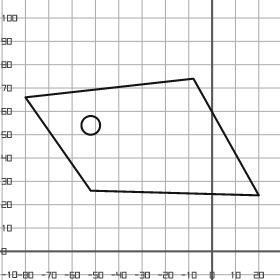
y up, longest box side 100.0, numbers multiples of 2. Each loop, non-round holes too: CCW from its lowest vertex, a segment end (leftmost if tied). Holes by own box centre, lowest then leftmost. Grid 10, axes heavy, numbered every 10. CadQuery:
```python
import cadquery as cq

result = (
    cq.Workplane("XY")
    .moveTo(20.0, 24.0)
    .lineTo(-8.0, 74.0)
    .lineTo(-80.0, 66.0)
    .lineTo(-52.0, 26.0)
    .close()
    .moveTo(-52.0, 54.0)
    .circle(4.0)
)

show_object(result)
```